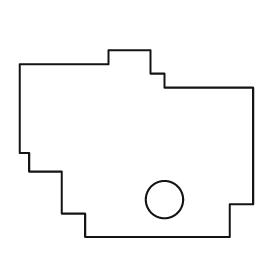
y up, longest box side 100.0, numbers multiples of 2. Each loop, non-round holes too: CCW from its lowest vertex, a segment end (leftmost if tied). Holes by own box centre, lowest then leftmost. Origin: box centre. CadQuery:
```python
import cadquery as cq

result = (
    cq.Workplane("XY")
    .moveTo(-22.0, -40.0)
    .lineTo(40.0, -40.0)
    .lineTo(40.0, -26.0)
    .lineTo(50.0, -26.0)
    .lineTo(50.0, 24.0)
    .lineTo(12.0, 24.0)
    .lineTo(12.0, 30.0)
    .lineTo(6.0, 30.0)
    .lineTo(6.0, 40.0)
    .lineTo(-12.0, 40.0)
    .lineTo(-12.0, 34.0)
    .lineTo(-50.0, 34.0)
    .lineTo(-50.0, -4.0)
    .lineTo(-46.0, -4.0)
    .lineTo(-46.0, -12.0)
    .lineTo(-32.0, -12.0)
    .lineTo(-32.0, -30.0)
    .lineTo(-22.0, -30.0)
    .close()
    .moveTo(12.0, -24.0)
    .circle(8.0)
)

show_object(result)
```